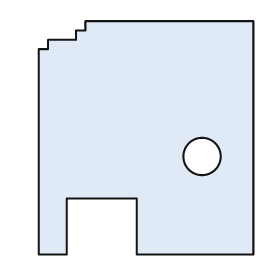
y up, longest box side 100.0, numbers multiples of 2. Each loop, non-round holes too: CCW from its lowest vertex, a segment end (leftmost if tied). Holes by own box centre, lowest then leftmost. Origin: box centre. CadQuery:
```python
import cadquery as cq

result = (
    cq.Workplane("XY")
    .moveTo(-46.0, -50.0)
    .lineTo(-34.0, -50.0)
    .lineTo(-34.0, -26.0)
    .lineTo(-4.0, -26.0)
    .lineTo(-4.0, -50.0)
    .lineTo(46.0, -50.0)
    .lineTo(46.0, 50.0)
    .lineTo(-26.0, 50.0)
    .lineTo(-26.0, 46.0)
    .lineTo(-30.0, 46.0)
    .lineTo(-30.0, 42.0)
    .lineTo(-42.0, 42.0)
    .lineTo(-42.0, 38.0)
    .lineTo(-46.0, 38.0)
    .close()
    .moveTo(24.0, -8.0)
    .circle(8.0)
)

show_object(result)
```